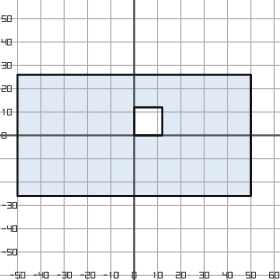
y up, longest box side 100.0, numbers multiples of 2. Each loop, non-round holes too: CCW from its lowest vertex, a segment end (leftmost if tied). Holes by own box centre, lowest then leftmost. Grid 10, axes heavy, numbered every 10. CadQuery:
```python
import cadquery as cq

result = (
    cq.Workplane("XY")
    .moveTo(-50.0, -26.0)
    .lineTo(50.0, -26.0)
    .lineTo(50.0, 26.0)
    .lineTo(-50.0, 26.0)
    .close()
    .moveTo(0.0, 0.0)
    .lineTo(12.0, 0.0)
    .lineTo(12.0, 12.0)
    .lineTo(0.0, 12.0)
    .close()
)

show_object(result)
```